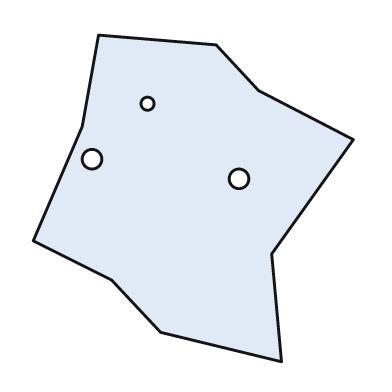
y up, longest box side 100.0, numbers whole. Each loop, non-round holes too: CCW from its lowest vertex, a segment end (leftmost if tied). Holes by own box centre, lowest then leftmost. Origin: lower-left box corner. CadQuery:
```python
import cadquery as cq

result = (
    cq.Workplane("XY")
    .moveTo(76.0, 0.0)
    .lineTo(73.0, 33.0)
    .lineTo(98.0, 68.0)
    .lineTo(69.0, 83.0)
    .lineTo(56.0, 97.0)
    .lineTo(20.0, 100.0)
    .lineTo(15.0, 72.0)
    .lineTo(0.0, 37.0)
    .lineTo(24.0, 25.0)
    .lineTo(39.0, 9.0)
    .close()
    .moveTo(63.0, 56.0)
    .circle(3.0)
    .moveTo(18.0, 62.0)
    .circle(3.0)
    .moveTo(35.0, 79.0)
    .circle(2.0)
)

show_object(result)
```